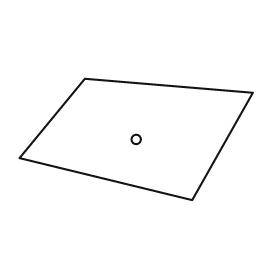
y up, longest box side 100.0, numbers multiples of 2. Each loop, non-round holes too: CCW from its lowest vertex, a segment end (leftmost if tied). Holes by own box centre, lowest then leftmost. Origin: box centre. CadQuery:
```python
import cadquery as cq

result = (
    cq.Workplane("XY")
    .moveTo(24.0, -26.0)
    .lineTo(50.0, 20.0)
    .lineTo(-22.0, 26.0)
    .lineTo(-50.0, -8.0)
    .close()
    .moveTo(0.0, 0.0)
    .circle(2.0)
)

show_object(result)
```